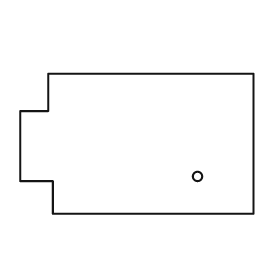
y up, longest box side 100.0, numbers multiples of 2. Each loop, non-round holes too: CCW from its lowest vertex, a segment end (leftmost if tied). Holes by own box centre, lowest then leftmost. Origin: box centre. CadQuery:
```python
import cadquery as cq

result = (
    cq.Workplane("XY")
    .moveTo(-36.0, -30.0)
    .lineTo(50.0, -30.0)
    .lineTo(50.0, 30.0)
    .lineTo(-38.0, 30.0)
    .lineTo(-38.0, 14.0)
    .lineTo(-50.0, 14.0)
    .lineTo(-50.0, -16.0)
    .lineTo(-36.0, -16.0)
    .close()
    .moveTo(26.0, -14.0)
    .circle(2.0)
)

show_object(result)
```